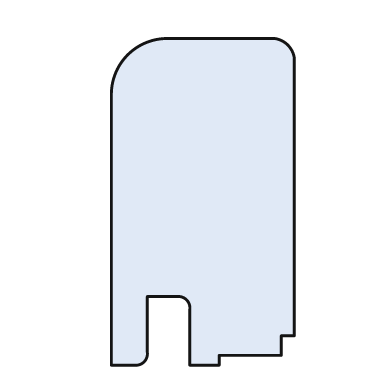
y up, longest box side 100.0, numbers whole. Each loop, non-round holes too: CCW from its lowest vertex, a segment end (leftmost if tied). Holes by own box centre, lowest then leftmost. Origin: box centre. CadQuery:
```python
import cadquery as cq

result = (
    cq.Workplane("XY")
    .moveTo(-28.0, -50.0)
    .lineTo(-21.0, -50.0)
    .threePointArc((-18.0, -49.0), (-17.0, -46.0))
    .lineTo(-17.0, -29.0)
    .lineTo(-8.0, -29.0)
    .threePointArc((-5.0, -30.0), (-4.0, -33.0))
    .lineTo(-4.0, -50.0)
    .lineTo(5.0, -50.0)
    .lineTo(5.0, -47.0)
    .lineTo(24.0, -47.0)
    .lineTo(24.0, -41.0)
    .lineTo(28.0, -41.0)
    .lineTo(28.0, 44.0)
    .threePointArc((26.0, 48.0), (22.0, 50.0))
    .lineTo(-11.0, 50.0)
    .threePointArc((-23.0, 45.0), (-28.0, 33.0))
    .close()
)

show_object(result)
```